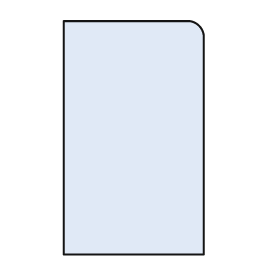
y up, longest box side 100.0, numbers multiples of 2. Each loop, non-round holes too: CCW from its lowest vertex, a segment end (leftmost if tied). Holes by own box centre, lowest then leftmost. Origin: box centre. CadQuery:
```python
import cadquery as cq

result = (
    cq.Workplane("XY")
    .moveTo(-30.0, -50.0)
    .lineTo(30.0, -50.0)
    .lineTo(30.0, 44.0)
    .threePointArc((28.0, 48.0), (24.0, 50.0))
    .lineTo(-30.0, 50.0)
    .close()
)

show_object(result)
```